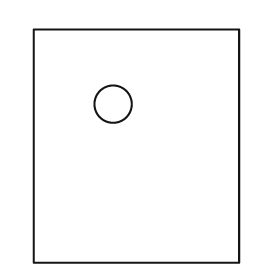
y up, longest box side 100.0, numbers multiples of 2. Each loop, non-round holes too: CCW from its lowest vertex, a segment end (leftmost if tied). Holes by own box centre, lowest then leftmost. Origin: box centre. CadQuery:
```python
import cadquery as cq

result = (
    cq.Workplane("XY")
    .moveTo(-44.0, -50.0)
    .lineTo(44.0, -50.0)
    .lineTo(44.0, 50.0)
    .lineTo(-44.0, 50.0)
    .close()
    .moveTo(-10.0, 18.0)
    .circle(8.0)
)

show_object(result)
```